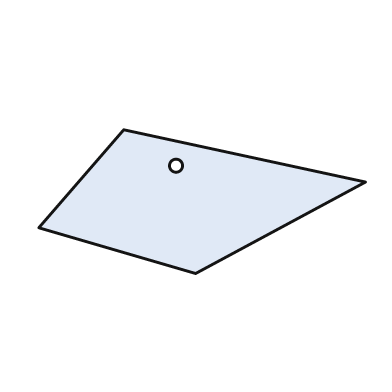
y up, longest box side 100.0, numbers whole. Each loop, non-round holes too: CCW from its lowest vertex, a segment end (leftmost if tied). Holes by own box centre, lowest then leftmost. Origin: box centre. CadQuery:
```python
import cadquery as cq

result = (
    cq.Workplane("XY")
    .moveTo(-2.0, -22.0)
    .lineTo(50.0, 6.0)
    .lineTo(-24.0, 22.0)
    .lineTo(-50.0, -8.0)
    .close()
    .moveTo(-8.0, 11.0)
    .circle(2.0)
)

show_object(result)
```